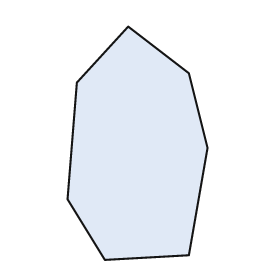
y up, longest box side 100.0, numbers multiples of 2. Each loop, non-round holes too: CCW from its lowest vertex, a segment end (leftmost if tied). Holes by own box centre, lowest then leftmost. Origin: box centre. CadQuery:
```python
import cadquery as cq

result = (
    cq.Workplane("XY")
    .moveTo(-14.0, -50.0)
    .lineTo(22.0, -48.0)
    .lineTo(30.0, -2.0)
    .lineTo(22.0, 30.0)
    .lineTo(-4.0, 50.0)
    .lineTo(-26.0, 26.0)
    .lineTo(-30.0, -24.0)
    .close()
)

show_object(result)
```